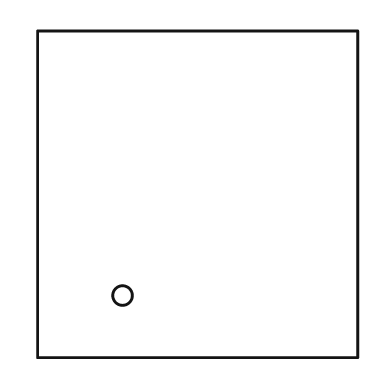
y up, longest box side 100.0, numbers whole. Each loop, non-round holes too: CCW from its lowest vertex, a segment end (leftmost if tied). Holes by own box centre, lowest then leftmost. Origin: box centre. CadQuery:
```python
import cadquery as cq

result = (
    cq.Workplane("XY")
    .moveTo(-49.0, -50.0)
    .lineTo(49.0, -50.0)
    .lineTo(49.0, 50.0)
    .lineTo(-49.0, 50.0)
    .close()
    .moveTo(-23.0, -31.0)
    .circle(3.0)
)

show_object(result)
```